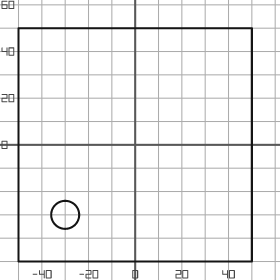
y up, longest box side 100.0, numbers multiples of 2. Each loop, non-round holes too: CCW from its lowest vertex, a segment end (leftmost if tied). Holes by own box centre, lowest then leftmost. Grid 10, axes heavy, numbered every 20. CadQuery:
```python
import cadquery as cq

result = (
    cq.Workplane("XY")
    .moveTo(-50.0, -50.0)
    .lineTo(50.0, -50.0)
    .lineTo(50.0, 50.0)
    .lineTo(-50.0, 50.0)
    .close()
    .moveTo(-30.0, -30.0)
    .circle(6.0)
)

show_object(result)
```